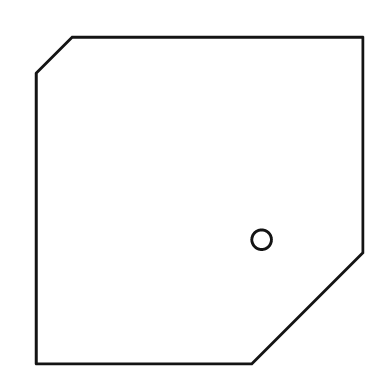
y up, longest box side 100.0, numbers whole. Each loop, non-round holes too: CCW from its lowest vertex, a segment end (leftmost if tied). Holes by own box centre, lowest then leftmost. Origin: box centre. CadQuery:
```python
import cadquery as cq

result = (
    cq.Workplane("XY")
    .moveTo(-50.0, -50.0)
    .lineTo(16.0, -50.0)
    .lineTo(50.0, -16.0)
    .lineTo(50.0, 50.0)
    .lineTo(-39.0, 50.0)
    .lineTo(-50.0, 39.0)
    .close()
    .moveTo(19.0, -12.0)
    .circle(3.0)
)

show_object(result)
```